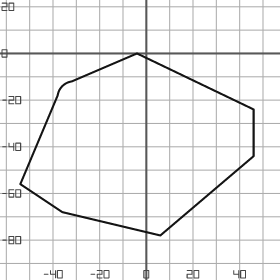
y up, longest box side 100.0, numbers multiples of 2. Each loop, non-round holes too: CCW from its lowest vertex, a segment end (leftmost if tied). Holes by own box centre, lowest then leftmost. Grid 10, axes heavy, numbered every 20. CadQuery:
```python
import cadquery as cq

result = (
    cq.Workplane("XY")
    .moveTo(6.0, -78.0)
    .lineTo(46.0, -44.0)
    .lineTo(46.0, -24.0)
    .lineTo(-4.0, 0.0)
    .lineTo(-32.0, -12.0)
    .threePointArc((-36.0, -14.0), (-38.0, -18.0))
    .lineTo(-54.0, -56.0)
    .lineTo(-36.0, -68.0)
    .close()
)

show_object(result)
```